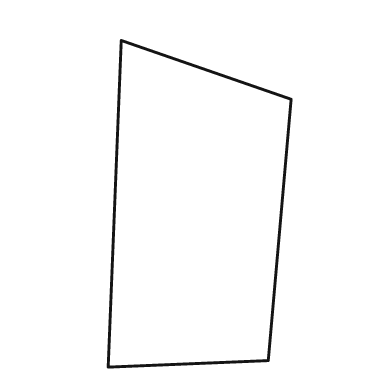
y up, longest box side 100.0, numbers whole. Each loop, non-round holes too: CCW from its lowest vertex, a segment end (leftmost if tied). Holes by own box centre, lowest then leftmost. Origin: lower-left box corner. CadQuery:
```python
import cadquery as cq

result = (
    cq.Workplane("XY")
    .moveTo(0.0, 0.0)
    .lineTo(49.0, 2.0)
    .lineTo(56.0, 82.0)
    .lineTo(4.0, 100.0)
    .close()
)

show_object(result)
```